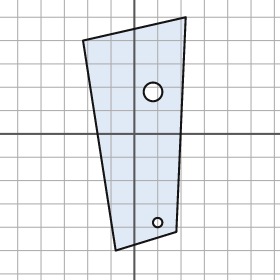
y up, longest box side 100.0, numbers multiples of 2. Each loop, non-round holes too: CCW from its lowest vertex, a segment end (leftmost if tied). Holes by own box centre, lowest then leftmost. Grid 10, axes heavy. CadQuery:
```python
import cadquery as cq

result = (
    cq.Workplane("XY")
    .moveTo(-8.0, -50.0)
    .lineTo(18.0, -42.0)
    .lineTo(22.0, 50.0)
    .lineTo(-22.0, 40.0)
    .close()
    .moveTo(10.0, -38.0)
    .circle(2.0)
    .moveTo(8.0, 18.0)
    .circle(4.0)
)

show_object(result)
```